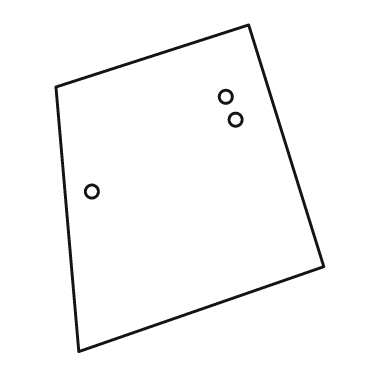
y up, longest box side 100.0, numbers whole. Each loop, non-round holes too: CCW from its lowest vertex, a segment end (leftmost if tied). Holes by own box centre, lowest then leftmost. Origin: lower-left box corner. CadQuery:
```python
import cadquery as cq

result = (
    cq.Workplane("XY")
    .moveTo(7.0, 0.0)
    .lineTo(82.0, 26.0)
    .lineTo(59.0, 100.0)
    .lineTo(0.0, 81.0)
    .close()
    .moveTo(11.0, 49.0)
    .circle(2.0)
    .moveTo(55.0, 71.0)
    .circle(2.0)
    .moveTo(52.0, 78.0)
    .circle(2.0)
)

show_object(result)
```